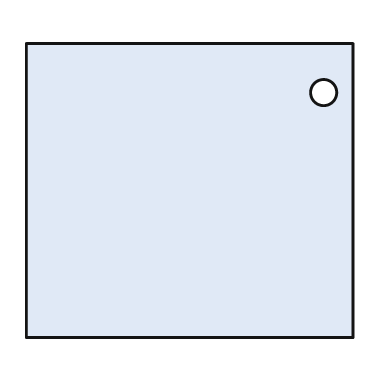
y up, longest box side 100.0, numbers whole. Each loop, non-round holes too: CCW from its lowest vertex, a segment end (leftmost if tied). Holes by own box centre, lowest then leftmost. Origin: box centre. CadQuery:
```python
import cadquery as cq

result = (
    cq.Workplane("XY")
    .moveTo(-50.0, -45.0)
    .lineTo(50.0, -45.0)
    .lineTo(50.0, 45.0)
    .lineTo(-50.0, 45.0)
    .close()
    .moveTo(41.0, 30.0)
    .circle(4.0)
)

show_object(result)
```